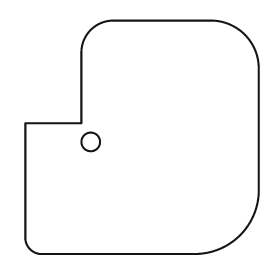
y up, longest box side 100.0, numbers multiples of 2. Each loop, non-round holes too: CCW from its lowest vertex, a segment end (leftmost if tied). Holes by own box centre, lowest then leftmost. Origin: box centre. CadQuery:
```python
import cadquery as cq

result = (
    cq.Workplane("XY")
    .moveTo(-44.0, -50.0)
    .lineTo(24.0, -50.0)
    .threePointArc((42.0, -42.0), (50.0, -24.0))
    .lineTo(50.0, 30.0)
    .threePointArc((44.0, 44.0), (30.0, 50.0))
    .lineTo(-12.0, 50.0)
    .threePointArc((-22.0, 46.0), (-26.0, 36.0))
    .lineTo(-26.0, 6.0)
    .lineTo(-50.0, 6.0)
    .lineTo(-50.0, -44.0)
    .threePointArc((-48.0, -48.0), (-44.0, -50.0))
    .close()
    .moveTo(-22.0, -2.0)
    .circle(4.0)
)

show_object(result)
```